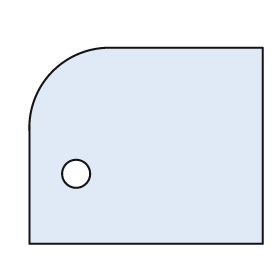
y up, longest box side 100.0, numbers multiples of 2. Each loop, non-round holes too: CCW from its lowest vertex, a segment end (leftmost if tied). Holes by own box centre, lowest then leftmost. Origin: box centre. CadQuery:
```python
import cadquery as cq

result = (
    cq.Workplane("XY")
    .moveTo(-50.0, -42.0)
    .lineTo(50.0, -42.0)
    .lineTo(50.0, 42.0)
    .lineTo(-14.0, 42.0)
    .threePointArc((-40.0, 32.0), (-50.0, 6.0))
    .close()
    .moveTo(-30.0, -12.0)
    .circle(6.0)
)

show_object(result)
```